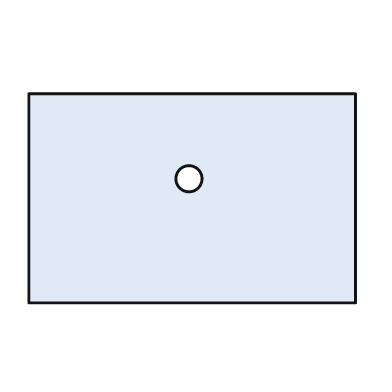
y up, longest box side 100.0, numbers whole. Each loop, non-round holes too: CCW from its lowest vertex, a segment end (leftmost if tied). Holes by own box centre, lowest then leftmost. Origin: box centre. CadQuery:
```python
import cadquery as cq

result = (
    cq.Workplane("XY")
    .moveTo(-50.0, -32.0)
    .lineTo(50.0, -32.0)
    .lineTo(50.0, 32.0)
    .lineTo(-50.0, 32.0)
    .close()
    .moveTo(-1.0, 6.0)
    .circle(4.0)
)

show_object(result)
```